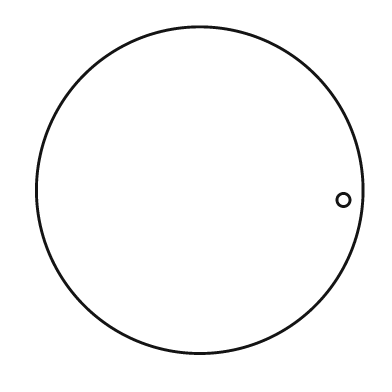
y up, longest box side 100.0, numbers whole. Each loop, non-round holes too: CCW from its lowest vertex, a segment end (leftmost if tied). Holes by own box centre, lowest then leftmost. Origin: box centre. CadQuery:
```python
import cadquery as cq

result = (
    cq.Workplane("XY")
    .moveTo(0.0, 0.0)
    .circle(50.0)
    .moveTo(44.0, -3.0)
    .circle(2.0)
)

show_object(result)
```